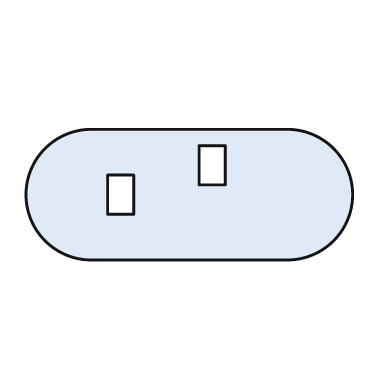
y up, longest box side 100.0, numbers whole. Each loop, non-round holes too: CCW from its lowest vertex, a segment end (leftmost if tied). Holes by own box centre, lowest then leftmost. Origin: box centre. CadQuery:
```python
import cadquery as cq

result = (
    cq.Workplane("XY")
    .moveTo(-30.0, -20.0)
    .lineTo(30.0, -20.0)
    .threePointArc((50.0, 0.0), (30.0, 20.0))
    .lineTo(-30.0, 20.0)
    .threePointArc((-50.0, 0.0), (-30.0, -20.0))
    .close()
    .moveTo(-25.0, -6.0)
    .lineTo(-17.0, -6.0)
    .lineTo(-17.0, 6.0)
    .lineTo(-25.0, 6.0)
    .close()
    .moveTo(3.0, 3.0)
    .lineTo(11.0, 3.0)
    .lineTo(11.0, 15.0)
    .lineTo(3.0, 15.0)
    .close()
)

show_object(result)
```